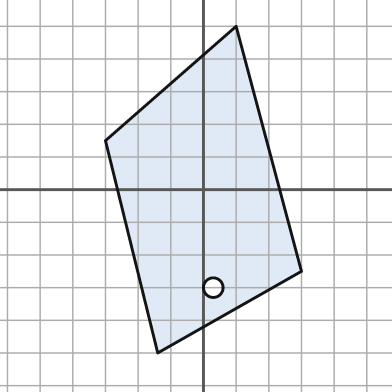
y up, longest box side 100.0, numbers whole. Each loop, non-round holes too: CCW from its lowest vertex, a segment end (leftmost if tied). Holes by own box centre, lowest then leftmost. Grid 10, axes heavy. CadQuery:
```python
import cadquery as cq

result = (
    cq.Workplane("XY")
    .moveTo(-14.0, -50.0)
    .lineTo(30.0, -25.0)
    .lineTo(10.0, 50.0)
    .lineTo(-30.0, 15.0)
    .close()
    .moveTo(3.0, -30.0)
    .circle(3.0)
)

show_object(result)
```